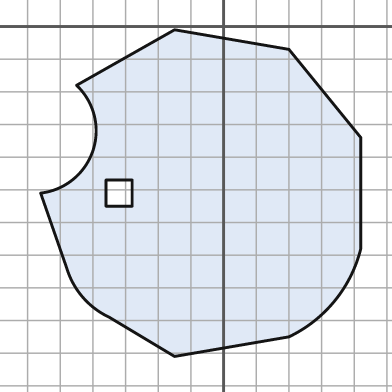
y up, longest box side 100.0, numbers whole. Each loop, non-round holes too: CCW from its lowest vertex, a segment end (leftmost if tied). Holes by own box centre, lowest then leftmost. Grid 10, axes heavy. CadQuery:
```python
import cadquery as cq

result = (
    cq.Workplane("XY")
    .moveTo(-15.0, -101.0)
    .lineTo(20.0, -95.0)
    .threePointArc((34.0, -84.0), (42.0, -68.0))
    .lineTo(42.0, -34.0)
    .lineTo(20.0, -7.0)
    .lineTo(-15.0, -1.0)
    .lineTo(-45.0, -18.0)
    .threePointArc((-40.0, -38.0), (-56.0, -51.0))
    .lineTo(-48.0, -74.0)
    .threePointArc((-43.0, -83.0), (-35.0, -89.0))
    .close()
    .moveTo(-36.0, -55.0)
    .lineTo(-28.0, -55.0)
    .lineTo(-28.0, -47.0)
    .lineTo(-36.0, -47.0)
    .close()
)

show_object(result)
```